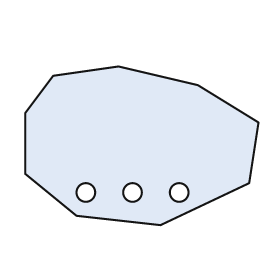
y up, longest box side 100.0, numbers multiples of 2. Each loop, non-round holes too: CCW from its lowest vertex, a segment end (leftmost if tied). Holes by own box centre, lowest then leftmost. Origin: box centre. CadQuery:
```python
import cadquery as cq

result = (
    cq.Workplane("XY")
    .moveTo(8.0, -34.0)
    .lineTo(46.0, -16.0)
    .lineTo(50.0, 10.0)
    .lineTo(24.0, 26.0)
    .lineTo(-10.0, 34.0)
    .lineTo(-38.0, 30.0)
    .lineTo(-50.0, 14.0)
    .lineTo(-50.0, -12.0)
    .lineTo(-28.0, -30.0)
    .close()
    .moveTo(-24.0, -20.0)
    .circle(4.0)
    .moveTo(-4.0, -20.0)
    .circle(4.0)
    .moveTo(16.0, -20.0)
    .circle(4.0)
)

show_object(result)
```